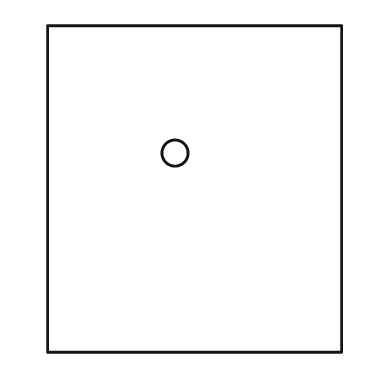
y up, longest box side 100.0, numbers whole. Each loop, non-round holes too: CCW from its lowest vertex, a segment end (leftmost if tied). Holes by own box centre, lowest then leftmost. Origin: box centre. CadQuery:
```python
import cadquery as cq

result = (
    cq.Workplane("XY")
    .moveTo(-45.0, -50.0)
    .lineTo(45.0, -50.0)
    .lineTo(45.0, 50.0)
    .lineTo(-45.0, 50.0)
    .close()
    .moveTo(-6.0, 11.0)
    .circle(4.0)
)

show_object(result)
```